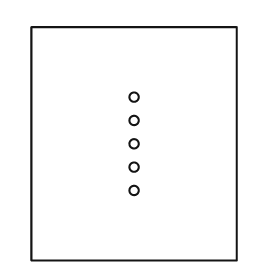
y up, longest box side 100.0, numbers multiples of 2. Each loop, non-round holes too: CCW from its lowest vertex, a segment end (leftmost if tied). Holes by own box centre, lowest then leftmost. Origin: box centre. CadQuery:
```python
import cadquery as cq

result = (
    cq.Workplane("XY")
    .moveTo(-44.0, -50.0)
    .lineTo(44.0, -50.0)
    .lineTo(44.0, 50.0)
    .lineTo(-44.0, 50.0)
    .close()
    .moveTo(0.0, -20.0)
    .circle(2.0)
    .moveTo(0.0, -10.0)
    .circle(2.0)
    .moveTo(0.0, 0.0)
    .circle(2.0)
    .moveTo(0.0, 10.0)
    .circle(2.0)
    .moveTo(0.0, 20.0)
    .circle(2.0)
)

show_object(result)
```